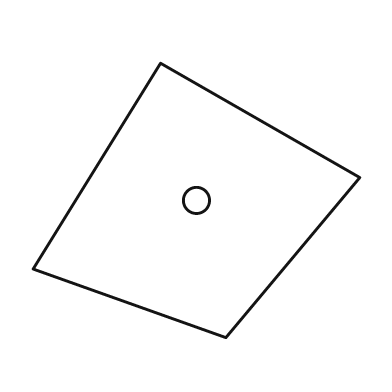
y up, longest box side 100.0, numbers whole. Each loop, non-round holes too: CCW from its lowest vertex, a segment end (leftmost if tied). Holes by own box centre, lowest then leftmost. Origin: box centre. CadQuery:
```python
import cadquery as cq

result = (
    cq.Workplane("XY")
    .moveTo(9.0, -42.0)
    .lineTo(50.0, 7.0)
    .lineTo(-11.0, 42.0)
    .lineTo(-50.0, -21.0)
    .close()
    .moveTo(0.0, 0.0)
    .circle(4.0)
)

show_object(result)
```